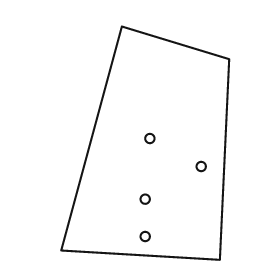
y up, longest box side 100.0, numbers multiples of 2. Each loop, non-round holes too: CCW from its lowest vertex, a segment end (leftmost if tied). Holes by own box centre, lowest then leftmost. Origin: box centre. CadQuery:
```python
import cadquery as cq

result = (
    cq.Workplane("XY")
    .moveTo(32.0, -50.0)
    .lineTo(36.0, 36.0)
    .lineTo(-10.0, 50.0)
    .lineTo(-36.0, -46.0)
    .close()
    .moveTo(0.0, -40.0)
    .circle(2.0)
    .moveTo(0.0, -24.0)
    .circle(2.0)
    .moveTo(24.0, -10.0)
    .circle(2.0)
    .moveTo(2.0, 2.0)
    .circle(2.0)
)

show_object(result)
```